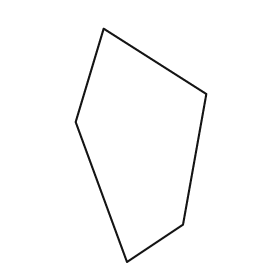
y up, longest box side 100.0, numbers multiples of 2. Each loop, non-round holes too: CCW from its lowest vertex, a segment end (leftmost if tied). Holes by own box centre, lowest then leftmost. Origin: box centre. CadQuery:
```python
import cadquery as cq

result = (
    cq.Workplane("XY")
    .moveTo(-6.0, -50.0)
    .lineTo(18.0, -34.0)
    .lineTo(28.0, 22.0)
    .lineTo(-16.0, 50.0)
    .lineTo(-28.0, 10.0)
    .close()
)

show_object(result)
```